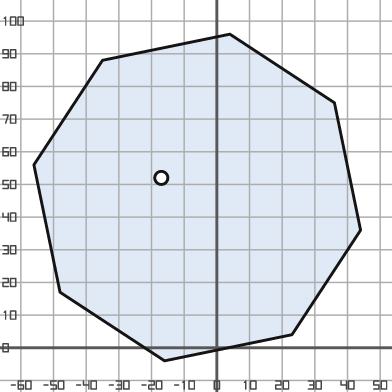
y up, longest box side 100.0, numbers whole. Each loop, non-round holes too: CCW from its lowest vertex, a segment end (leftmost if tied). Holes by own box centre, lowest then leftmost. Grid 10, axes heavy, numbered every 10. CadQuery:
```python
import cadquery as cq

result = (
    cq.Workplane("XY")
    .moveTo(-16.0, -4.0)
    .lineTo(23.0, 4.0)
    .lineTo(44.0, 36.0)
    .lineTo(36.0, 75.0)
    .lineTo(4.0, 96.0)
    .lineTo(-35.0, 88.0)
    .lineTo(-56.0, 56.0)
    .lineTo(-48.0, 17.0)
    .close()
    .moveTo(-17.0, 52.0)
    .circle(2.0)
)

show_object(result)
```